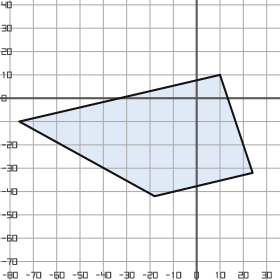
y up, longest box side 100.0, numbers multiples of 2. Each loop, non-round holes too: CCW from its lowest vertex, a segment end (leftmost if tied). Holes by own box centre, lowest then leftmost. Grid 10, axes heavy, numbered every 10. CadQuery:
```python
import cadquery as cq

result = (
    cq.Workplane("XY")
    .moveTo(-18.0, -42.0)
    .lineTo(24.0, -32.0)
    .lineTo(10.0, 10.0)
    .lineTo(-76.0, -10.0)
    .close()
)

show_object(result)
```